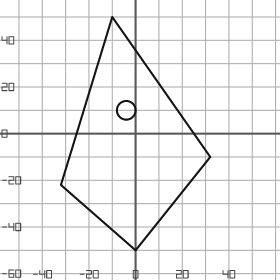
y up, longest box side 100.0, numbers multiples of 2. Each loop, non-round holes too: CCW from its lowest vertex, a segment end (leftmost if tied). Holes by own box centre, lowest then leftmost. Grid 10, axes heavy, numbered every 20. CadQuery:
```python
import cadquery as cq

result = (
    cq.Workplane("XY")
    .moveTo(0.0, -50.0)
    .lineTo(32.0, -10.0)
    .lineTo(-10.0, 50.0)
    .lineTo(-32.0, -22.0)
    .close()
    .moveTo(-4.0, 10.0)
    .circle(4.0)
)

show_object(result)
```